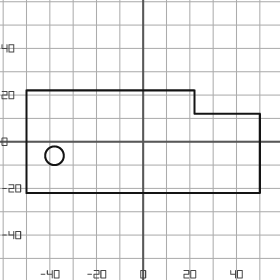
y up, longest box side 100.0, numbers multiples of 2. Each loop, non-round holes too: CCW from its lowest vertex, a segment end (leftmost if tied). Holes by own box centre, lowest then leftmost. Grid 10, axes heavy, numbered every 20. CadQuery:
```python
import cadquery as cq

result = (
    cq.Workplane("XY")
    .moveTo(-50.0, -22.0)
    .lineTo(50.0, -22.0)
    .lineTo(50.0, 12.0)
    .lineTo(22.0, 12.0)
    .lineTo(22.0, 22.0)
    .lineTo(-50.0, 22.0)
    .close()
    .moveTo(-38.0, -6.0)
    .circle(4.0)
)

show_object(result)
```